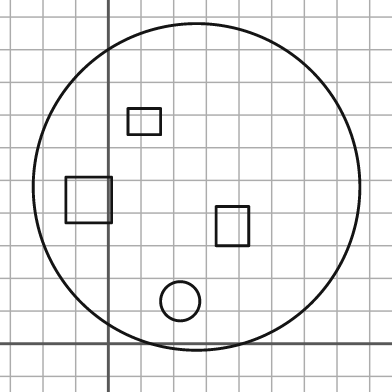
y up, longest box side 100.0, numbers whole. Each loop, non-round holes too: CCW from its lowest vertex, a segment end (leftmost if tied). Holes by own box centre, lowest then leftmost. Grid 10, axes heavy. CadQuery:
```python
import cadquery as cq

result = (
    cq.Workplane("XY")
    .moveTo(27.0, 48.0)
    .circle(50.0)
    .moveTo(22.0, 13.0)
    .circle(6.0)
    .moveTo(33.0, 30.0)
    .lineTo(43.0, 30.0)
    .lineTo(43.0, 42.0)
    .lineTo(33.0, 42.0)
    .close()
    .moveTo(-13.0, 37.0)
    .lineTo(1.0, 37.0)
    .lineTo(1.0, 51.0)
    .lineTo(-13.0, 51.0)
    .close()
    .moveTo(6.0, 64.0)
    .lineTo(16.0, 64.0)
    .lineTo(16.0, 72.0)
    .lineTo(6.0, 72.0)
    .close()
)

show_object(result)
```